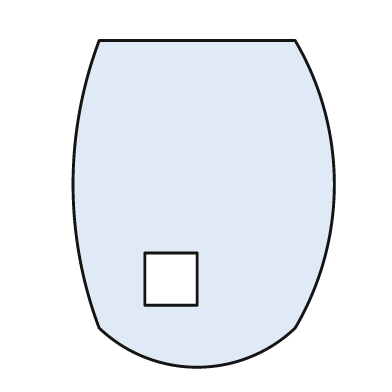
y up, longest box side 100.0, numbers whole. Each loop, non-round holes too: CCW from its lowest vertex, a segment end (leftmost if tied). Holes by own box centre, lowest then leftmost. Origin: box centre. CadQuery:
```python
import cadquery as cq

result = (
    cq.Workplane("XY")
    .moveTo(-32.0, -38.0)
    .threePointArc((-2.0, -50.0), (28.0, -38.0))
    .threePointArc((40.0, 6.0), (28.0, 50.0))
    .lineTo(-32.0, 50.0)
    .threePointArc((-40.0, 6.0), (-32.0, -38.0))
    .close()
    .moveTo(-18.0, -31.0)
    .lineTo(-2.0, -31.0)
    .lineTo(-2.0, -15.0)
    .lineTo(-18.0, -15.0)
    .close()
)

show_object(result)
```